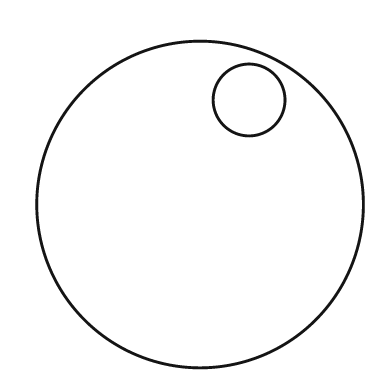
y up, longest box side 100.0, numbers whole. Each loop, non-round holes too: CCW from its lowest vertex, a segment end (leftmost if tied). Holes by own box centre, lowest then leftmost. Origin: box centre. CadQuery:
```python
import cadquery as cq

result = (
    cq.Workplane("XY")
    .moveTo(0.0, 0.0)
    .circle(50.0)
    .moveTo(15.0, 32.0)
    .circle(11.0)
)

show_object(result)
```